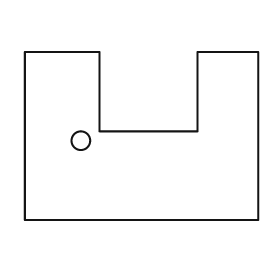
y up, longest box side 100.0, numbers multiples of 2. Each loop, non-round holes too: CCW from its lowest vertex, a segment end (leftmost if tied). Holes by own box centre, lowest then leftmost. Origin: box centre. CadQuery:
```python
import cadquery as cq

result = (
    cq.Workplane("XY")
    .moveTo(-50.0, -36.0)
    .lineTo(50.0, -36.0)
    .lineTo(50.0, 36.0)
    .lineTo(24.0, 36.0)
    .lineTo(24.0, 2.0)
    .lineTo(-18.0, 2.0)
    .lineTo(-18.0, 36.0)
    .lineTo(-50.0, 36.0)
    .close()
    .moveTo(-26.0, -2.0)
    .circle(4.0)
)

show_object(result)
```